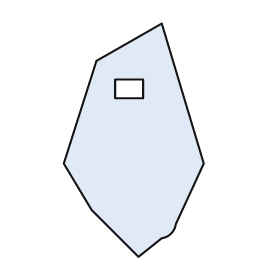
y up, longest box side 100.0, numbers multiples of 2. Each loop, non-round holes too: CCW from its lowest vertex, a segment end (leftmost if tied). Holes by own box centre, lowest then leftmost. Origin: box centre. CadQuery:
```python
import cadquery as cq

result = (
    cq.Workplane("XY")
    .moveTo(2.0, -50.0)
    .lineTo(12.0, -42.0)
    .threePointArc((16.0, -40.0), (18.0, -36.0))
    .lineTo(30.0, -10.0)
    .lineTo(12.0, 50.0)
    .lineTo(-16.0, 34.0)
    .lineTo(-30.0, -10.0)
    .lineTo(-18.0, -30.0)
    .close()
    .moveTo(-8.0, 18.0)
    .lineTo(4.0, 18.0)
    .lineTo(4.0, 26.0)
    .lineTo(-8.0, 26.0)
    .close()
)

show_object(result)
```